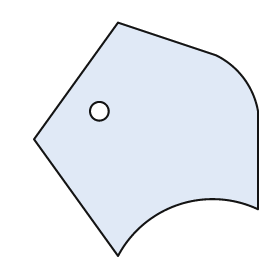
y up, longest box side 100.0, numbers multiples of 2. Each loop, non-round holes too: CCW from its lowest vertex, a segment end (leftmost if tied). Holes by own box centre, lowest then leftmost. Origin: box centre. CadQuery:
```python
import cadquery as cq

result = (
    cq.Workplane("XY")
    .moveTo(-12.0, -50.0)
    .threePointArc((14.0, -28.0), (48.0, -30.0))
    .lineTo(48.0, 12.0)
    .threePointArc((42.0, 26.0), (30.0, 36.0))
    .lineTo(-12.0, 50.0)
    .lineTo(-48.0, 0.0)
    .close()
    .moveTo(-20.0, 12.0)
    .circle(4.0)
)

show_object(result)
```